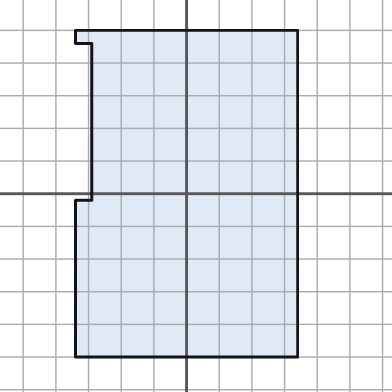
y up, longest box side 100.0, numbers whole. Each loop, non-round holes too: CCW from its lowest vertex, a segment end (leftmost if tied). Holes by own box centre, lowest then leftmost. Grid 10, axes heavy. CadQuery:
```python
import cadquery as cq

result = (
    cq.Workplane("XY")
    .moveTo(-34.0, -50.0)
    .lineTo(34.0, -50.0)
    .lineTo(34.0, 50.0)
    .lineTo(-34.0, 50.0)
    .lineTo(-34.0, 46.0)
    .lineTo(-29.0, 46.0)
    .lineTo(-29.0, -2.0)
    .lineTo(-34.0, -2.0)
    .close()
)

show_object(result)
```